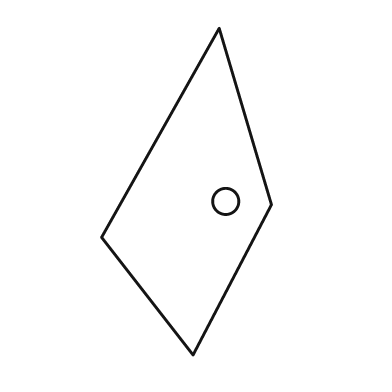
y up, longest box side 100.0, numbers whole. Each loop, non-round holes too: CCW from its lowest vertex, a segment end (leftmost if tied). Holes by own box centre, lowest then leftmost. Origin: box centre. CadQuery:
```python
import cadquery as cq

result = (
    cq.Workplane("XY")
    .moveTo(2.0, -50.0)
    .lineTo(26.0, -4.0)
    .lineTo(10.0, 50.0)
    .lineTo(-26.0, -14.0)
    .close()
    .moveTo(12.0, -3.0)
    .circle(4.0)
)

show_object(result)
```